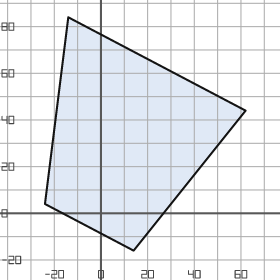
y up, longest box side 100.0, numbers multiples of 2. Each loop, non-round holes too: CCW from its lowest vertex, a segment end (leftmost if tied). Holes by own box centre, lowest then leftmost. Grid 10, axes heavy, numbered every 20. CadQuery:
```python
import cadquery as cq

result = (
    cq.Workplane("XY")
    .moveTo(14.0, -16.0)
    .lineTo(62.0, 44.0)
    .lineTo(-14.0, 84.0)
    .lineTo(-24.0, 4.0)
    .close()
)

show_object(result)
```